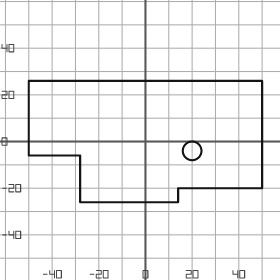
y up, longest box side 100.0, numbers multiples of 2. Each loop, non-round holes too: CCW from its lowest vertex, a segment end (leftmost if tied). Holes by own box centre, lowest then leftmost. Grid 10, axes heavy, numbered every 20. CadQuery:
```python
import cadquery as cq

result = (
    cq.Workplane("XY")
    .moveTo(-28.0, -26.0)
    .lineTo(14.0, -26.0)
    .lineTo(14.0, -20.0)
    .lineTo(50.0, -20.0)
    .lineTo(50.0, 26.0)
    .lineTo(-50.0, 26.0)
    .lineTo(-50.0, -6.0)
    .lineTo(-28.0, -6.0)
    .close()
    .moveTo(20.0, -4.0)
    .circle(4.0)
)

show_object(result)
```